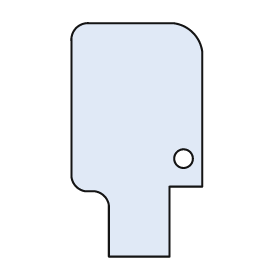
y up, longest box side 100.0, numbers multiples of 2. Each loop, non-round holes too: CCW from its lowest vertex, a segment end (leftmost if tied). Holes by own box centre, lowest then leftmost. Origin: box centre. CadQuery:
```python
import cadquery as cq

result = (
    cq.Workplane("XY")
    .moveTo(-12.0, -50.0)
    .lineTo(14.0, -50.0)
    .lineTo(14.0, -20.0)
    .lineTo(28.0, -20.0)
    .lineTo(28.0, 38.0)
    .threePointArc((24.0, 46.0), (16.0, 50.0))
    .lineTo(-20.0, 50.0)
    .threePointArc((-26.0, 48.0), (-28.0, 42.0))
    .lineTo(-28.0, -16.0)
    .threePointArc((-26.0, -20.0), (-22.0, -22.0))
    .lineTo(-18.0, -22.0)
    .threePointArc((-14.0, -24.0), (-12.0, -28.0))
    .close()
    .moveTo(20.0, -8.0)
    .circle(4.0)
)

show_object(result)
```